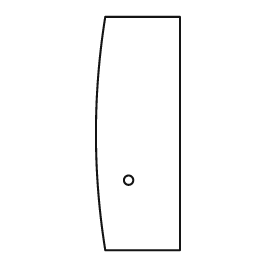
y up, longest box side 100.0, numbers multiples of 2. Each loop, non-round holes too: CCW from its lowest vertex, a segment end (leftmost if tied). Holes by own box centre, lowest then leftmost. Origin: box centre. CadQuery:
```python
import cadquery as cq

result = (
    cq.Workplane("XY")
    .moveTo(-14.0, -50.0)
    .lineTo(18.0, -50.0)
    .lineTo(18.0, 50.0)
    .lineTo(-14.0, 50.0)
    .threePointArc((-18.0, 0.0), (-14.0, -50.0))
    .close()
    .moveTo(-4.0, -20.0)
    .circle(2.0)
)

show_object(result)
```